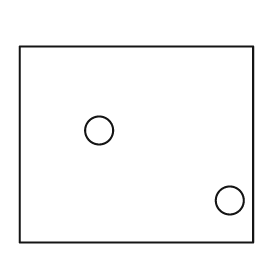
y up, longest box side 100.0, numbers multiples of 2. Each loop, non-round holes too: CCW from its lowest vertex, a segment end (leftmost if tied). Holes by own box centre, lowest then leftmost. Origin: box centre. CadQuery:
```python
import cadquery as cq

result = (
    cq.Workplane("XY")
    .moveTo(-50.0, -42.0)
    .lineTo(50.0, -42.0)
    .lineTo(50.0, 42.0)
    .lineTo(-50.0, 42.0)
    .close()
    .moveTo(40.0, -24.0)
    .circle(6.0)
    .moveTo(-16.0, 6.0)
    .circle(6.0)
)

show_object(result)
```